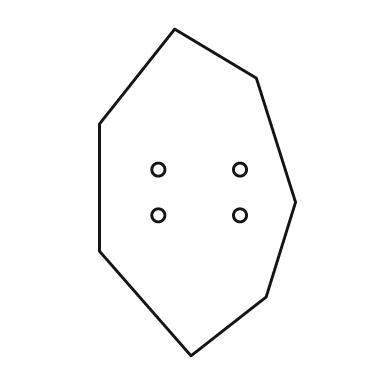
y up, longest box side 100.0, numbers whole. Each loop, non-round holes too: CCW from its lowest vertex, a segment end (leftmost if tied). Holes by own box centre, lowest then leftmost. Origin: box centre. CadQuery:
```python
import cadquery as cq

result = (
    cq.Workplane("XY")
    .moveTo(-2.0, -50.0)
    .lineTo(21.0, -32.0)
    .lineTo(30.0, -3.0)
    .lineTo(18.0, 35.0)
    .lineTo(-7.0, 50.0)
    .lineTo(-30.0, 21.0)
    .lineTo(-30.0, -18.0)
    .close()
    .moveTo(-12.0, -7.0)
    .circle(2.0)
    .moveTo(13.0, -7.0)
    .circle(2.0)
    .moveTo(-12.0, 7.0)
    .circle(2.0)
    .moveTo(13.0, 7.0)
    .circle(2.0)
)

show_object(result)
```